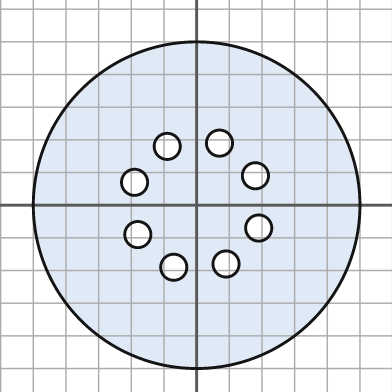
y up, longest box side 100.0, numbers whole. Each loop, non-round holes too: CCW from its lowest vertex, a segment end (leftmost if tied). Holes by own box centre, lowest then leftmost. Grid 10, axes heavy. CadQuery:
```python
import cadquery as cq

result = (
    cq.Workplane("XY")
    .moveTo(0.0, 0.0)
    .circle(50.0)
    .moveTo(-7.0, -19.0)
    .circle(4.0)
    .moveTo(9.0, -18.0)
    .circle(4.0)
    .moveTo(-18.0, -9.0)
    .circle(4.0)
    .moveTo(19.0, -7.0)
    .circle(4.0)
    .moveTo(-19.0, 7.0)
    .circle(4.0)
    .moveTo(18.0, 9.0)
    .circle(4.0)
    .moveTo(-9.0, 18.0)
    .circle(4.0)
    .moveTo(7.0, 19.0)
    .circle(4.0)
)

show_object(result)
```